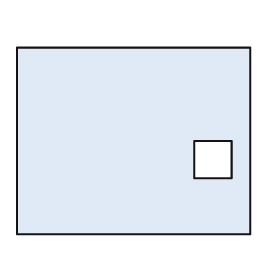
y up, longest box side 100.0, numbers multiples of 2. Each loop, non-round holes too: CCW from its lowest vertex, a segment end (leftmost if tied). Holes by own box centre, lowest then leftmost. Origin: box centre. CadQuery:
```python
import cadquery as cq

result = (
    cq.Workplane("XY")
    .moveTo(-50.0, -40.0)
    .lineTo(50.0, -40.0)
    .lineTo(50.0, 40.0)
    .lineTo(-50.0, 40.0)
    .close()
    .moveTo(26.0, -16.0)
    .lineTo(42.0, -16.0)
    .lineTo(42.0, 0.0)
    .lineTo(26.0, 0.0)
    .close()
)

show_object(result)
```